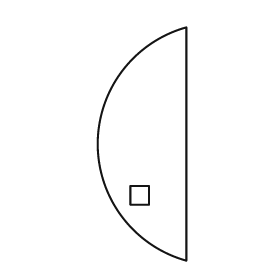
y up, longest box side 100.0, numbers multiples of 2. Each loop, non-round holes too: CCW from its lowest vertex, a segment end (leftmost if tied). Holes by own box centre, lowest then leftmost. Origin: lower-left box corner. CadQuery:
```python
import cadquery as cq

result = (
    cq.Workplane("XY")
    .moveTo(38.0, 0.0)
    .lineTo(38.0, 100.0)
    .threePointArc((0.0, 50.0), (38.0, 0.0))
    .close()
    .moveTo(14.0, 24.0)
    .lineTo(22.0, 24.0)
    .lineTo(22.0, 32.0)
    .lineTo(14.0, 32.0)
    .close()
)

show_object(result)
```